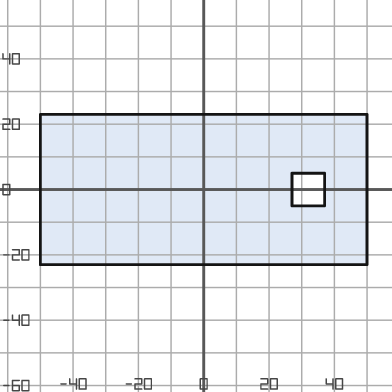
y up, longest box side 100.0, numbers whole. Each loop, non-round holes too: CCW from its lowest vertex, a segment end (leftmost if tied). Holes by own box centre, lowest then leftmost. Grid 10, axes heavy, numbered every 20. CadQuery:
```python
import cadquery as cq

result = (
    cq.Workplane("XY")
    .moveTo(-50.0, -23.0)
    .lineTo(50.0, -23.0)
    .lineTo(50.0, 23.0)
    .lineTo(-50.0, 23.0)
    .close()
    .moveTo(27.0, -5.0)
    .lineTo(37.0, -5.0)
    .lineTo(37.0, 5.0)
    .lineTo(27.0, 5.0)
    .close()
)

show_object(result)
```